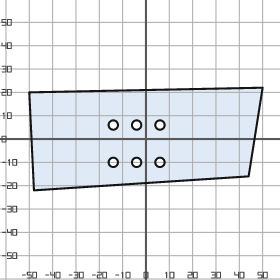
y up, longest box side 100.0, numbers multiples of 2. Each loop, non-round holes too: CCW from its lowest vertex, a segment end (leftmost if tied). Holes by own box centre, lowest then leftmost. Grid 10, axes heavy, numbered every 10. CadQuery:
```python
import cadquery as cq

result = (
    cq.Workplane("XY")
    .moveTo(-48.0, -22.0)
    .lineTo(44.0, -16.0)
    .lineTo(50.0, 22.0)
    .lineTo(-50.0, 20.0)
    .close()
    .moveTo(-14.0, -10.0)
    .circle(2.0)
    .moveTo(-4.0, -10.0)
    .circle(2.0)
    .moveTo(6.0, -10.0)
    .circle(2.0)
    .moveTo(-14.0, 6.0)
    .circle(2.0)
    .moveTo(-4.0, 6.0)
    .circle(2.0)
    .moveTo(6.0, 6.0)
    .circle(2.0)
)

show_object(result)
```